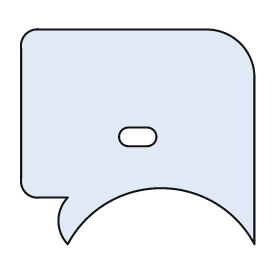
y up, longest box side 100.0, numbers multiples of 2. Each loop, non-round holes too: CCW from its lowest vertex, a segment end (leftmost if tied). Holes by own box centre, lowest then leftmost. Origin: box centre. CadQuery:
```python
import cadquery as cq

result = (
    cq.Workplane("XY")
    .moveTo(-30.0, -46.0)
    .threePointArc((10.0, -22.0), (50.0, -46.0))
    .lineTo(50.0, 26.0)
    .threePointArc((44.0, 40.0), (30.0, 46.0))
    .lineTo(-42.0, 46.0)
    .threePointArc((-48.0, 44.0), (-50.0, 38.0))
    .lineTo(-50.0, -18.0)
    .threePointArc((-48.0, -24.0), (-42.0, -26.0))
    .lineTo(-30.0, -26.0)
    .threePointArc((-34.0, -36.0), (-30.0, -46.0))
    .close()
    .moveTo(-4.0, -4.0)
    .lineTo(4.0, -4.0)
    .threePointArc((8.0, 0.0), (4.0, 4.0))
    .lineTo(-4.0, 4.0)
    .threePointArc((-8.0, 0.0), (-4.0, -4.0))
    .close()
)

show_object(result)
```